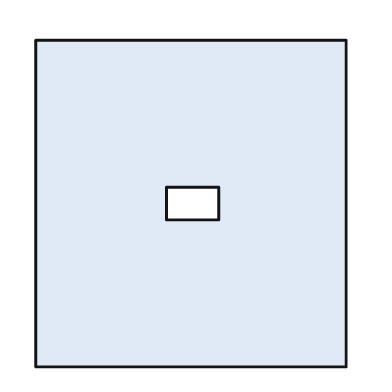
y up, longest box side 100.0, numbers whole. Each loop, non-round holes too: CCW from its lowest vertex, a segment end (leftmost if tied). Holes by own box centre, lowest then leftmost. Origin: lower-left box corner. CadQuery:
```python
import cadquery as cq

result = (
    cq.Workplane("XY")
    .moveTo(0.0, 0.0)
    .lineTo(95.0, 0.0)
    .lineTo(95.0, 100.0)
    .lineTo(0.0, 100.0)
    .close()
    .moveTo(40.0, 45.0)
    .lineTo(56.0, 45.0)
    .lineTo(56.0, 55.0)
    .lineTo(40.0, 55.0)
    .close()
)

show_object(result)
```